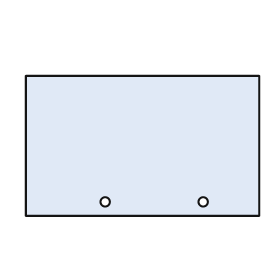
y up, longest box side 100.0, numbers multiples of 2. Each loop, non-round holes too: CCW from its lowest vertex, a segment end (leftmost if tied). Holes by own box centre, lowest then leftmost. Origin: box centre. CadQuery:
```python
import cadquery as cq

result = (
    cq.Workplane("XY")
    .moveTo(-50.0, -30.0)
    .lineTo(50.0, -30.0)
    .lineTo(50.0, 30.0)
    .lineTo(-50.0, 30.0)
    .close()
    .moveTo(-16.0, -24.0)
    .circle(2.0)
    .moveTo(26.0, -24.0)
    .circle(2.0)
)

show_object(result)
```